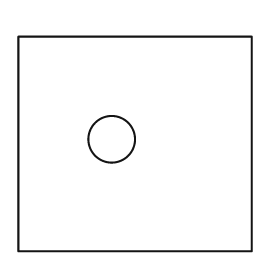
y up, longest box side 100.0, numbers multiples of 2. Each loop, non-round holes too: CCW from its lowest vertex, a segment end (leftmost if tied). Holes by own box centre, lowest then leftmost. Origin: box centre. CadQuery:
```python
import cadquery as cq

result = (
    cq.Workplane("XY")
    .moveTo(-50.0, -46.0)
    .lineTo(50.0, -46.0)
    .lineTo(50.0, 46.0)
    .lineTo(-50.0, 46.0)
    .close()
    .moveTo(-10.0, 2.0)
    .circle(10.0)
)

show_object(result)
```